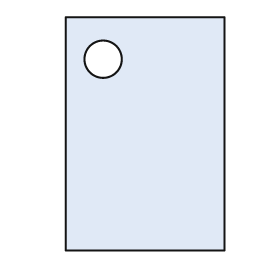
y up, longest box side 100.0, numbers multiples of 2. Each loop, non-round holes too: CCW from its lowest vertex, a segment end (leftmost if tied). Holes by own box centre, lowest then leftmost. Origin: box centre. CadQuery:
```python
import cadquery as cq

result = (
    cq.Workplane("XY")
    .moveTo(-34.0, -50.0)
    .lineTo(34.0, -50.0)
    .lineTo(34.0, 50.0)
    .lineTo(-34.0, 50.0)
    .close()
    .moveTo(-18.0, 32.0)
    .circle(8.0)
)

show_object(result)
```